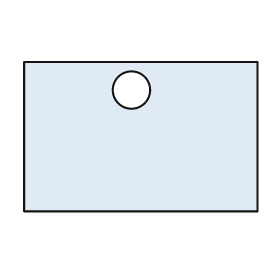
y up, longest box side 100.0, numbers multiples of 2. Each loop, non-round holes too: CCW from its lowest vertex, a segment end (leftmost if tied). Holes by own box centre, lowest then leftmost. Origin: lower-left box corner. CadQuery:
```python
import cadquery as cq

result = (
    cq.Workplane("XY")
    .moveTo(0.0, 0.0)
    .lineTo(100.0, 0.0)
    .lineTo(100.0, 64.0)
    .lineTo(0.0, 64.0)
    .close()
    .moveTo(46.0, 52.0)
    .circle(8.0)
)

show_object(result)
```